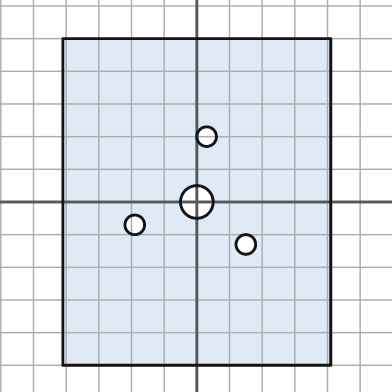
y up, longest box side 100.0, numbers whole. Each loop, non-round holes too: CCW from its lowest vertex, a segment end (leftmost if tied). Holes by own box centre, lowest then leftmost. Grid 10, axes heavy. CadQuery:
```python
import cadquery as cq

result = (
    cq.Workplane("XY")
    .moveTo(-41.0, -50.0)
    .lineTo(41.0, -50.0)
    .lineTo(41.0, 50.0)
    .lineTo(-41.0, 50.0)
    .close()
    .moveTo(15.0, -13.0)
    .circle(3.0)
    .moveTo(-19.0, -7.0)
    .circle(3.0)
    .moveTo(0.0, 0.0)
    .circle(5.0)
    .moveTo(3.0, 20.0)
    .circle(3.0)
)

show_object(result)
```